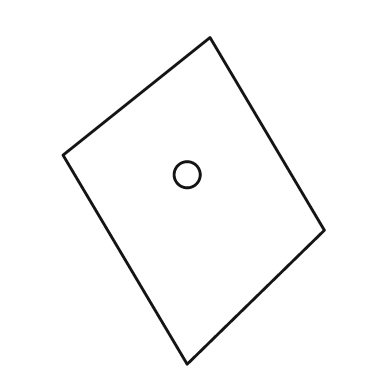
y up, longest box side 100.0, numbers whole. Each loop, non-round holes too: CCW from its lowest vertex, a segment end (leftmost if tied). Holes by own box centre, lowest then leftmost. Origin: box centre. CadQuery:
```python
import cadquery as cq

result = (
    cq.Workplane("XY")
    .moveTo(-2.0, -50.0)
    .lineTo(40.0, -9.0)
    .lineTo(5.0, 50.0)
    .lineTo(-40.0, 14.0)
    .close()
    .moveTo(-2.0, 8.0)
    .circle(4.0)
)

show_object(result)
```